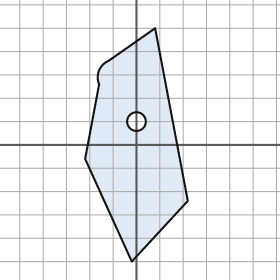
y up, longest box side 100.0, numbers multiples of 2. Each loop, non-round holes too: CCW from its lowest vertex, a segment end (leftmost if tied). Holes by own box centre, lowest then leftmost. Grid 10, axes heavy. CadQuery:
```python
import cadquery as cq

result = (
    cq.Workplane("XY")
    .moveTo(-2.0, -50.0)
    .lineTo(22.0, -24.0)
    .lineTo(8.0, 50.0)
    .lineTo(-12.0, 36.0)
    .threePointArc((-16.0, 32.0), (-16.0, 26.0))
    .lineTo(-22.0, -6.0)
    .close()
    .moveTo(0.0, 10.0)
    .circle(4.0)
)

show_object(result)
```